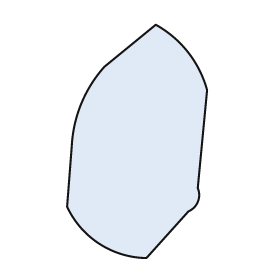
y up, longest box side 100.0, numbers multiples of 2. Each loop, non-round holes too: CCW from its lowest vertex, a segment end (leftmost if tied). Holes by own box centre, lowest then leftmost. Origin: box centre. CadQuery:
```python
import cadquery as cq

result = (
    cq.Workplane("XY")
    .moveTo(4.0, -50.0)
    .lineTo(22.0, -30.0)
    .threePointArc((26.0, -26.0), (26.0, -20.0))
    .lineTo(30.0, 22.0)
    .threePointArc((22.0, 38.0), (8.0, 50.0))
    .lineTo(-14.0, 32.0)
    .threePointArc((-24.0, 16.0), (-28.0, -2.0))
    .lineTo(-30.0, -28.0)
    .threePointArc((-16.0, -44.0), (4.0, -50.0))
    .close()
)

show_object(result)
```